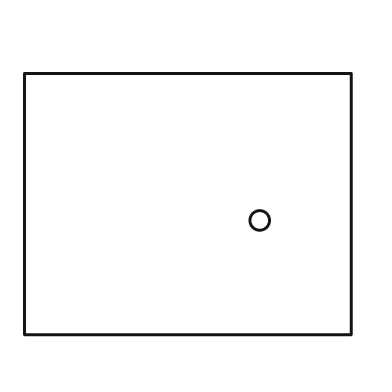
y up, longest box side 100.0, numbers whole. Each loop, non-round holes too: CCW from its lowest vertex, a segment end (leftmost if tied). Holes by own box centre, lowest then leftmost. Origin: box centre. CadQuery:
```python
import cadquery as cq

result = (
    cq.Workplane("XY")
    .moveTo(-50.0, -40.0)
    .lineTo(50.0, -40.0)
    .lineTo(50.0, 40.0)
    .lineTo(-50.0, 40.0)
    .close()
    .moveTo(22.0, -5.0)
    .circle(3.0)
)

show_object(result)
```